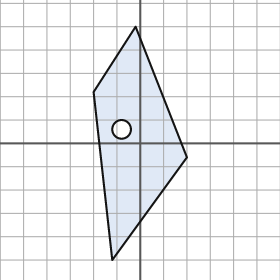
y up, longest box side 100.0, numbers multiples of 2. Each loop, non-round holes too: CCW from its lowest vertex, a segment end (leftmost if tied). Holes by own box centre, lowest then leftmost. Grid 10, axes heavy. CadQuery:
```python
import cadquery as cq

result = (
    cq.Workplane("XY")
    .moveTo(-12.0, -50.0)
    .lineTo(20.0, -6.0)
    .lineTo(-2.0, 50.0)
    .lineTo(-20.0, 22.0)
    .close()
    .moveTo(-8.0, 6.0)
    .circle(4.0)
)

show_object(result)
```